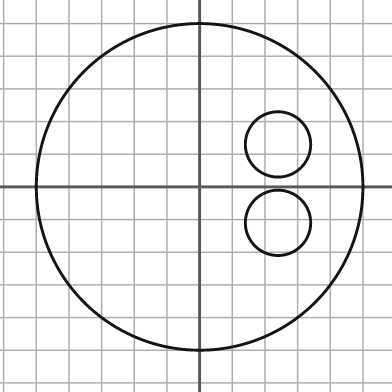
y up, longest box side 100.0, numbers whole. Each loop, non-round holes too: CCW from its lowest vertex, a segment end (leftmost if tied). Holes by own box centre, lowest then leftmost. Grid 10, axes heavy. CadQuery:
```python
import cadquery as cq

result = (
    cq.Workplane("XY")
    .moveTo(0.0, 0.0)
    .circle(50.0)
    .moveTo(24.0, -11.0)
    .circle(10.0)
    .moveTo(24.0, 13.0)
    .circle(10.0)
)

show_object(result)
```